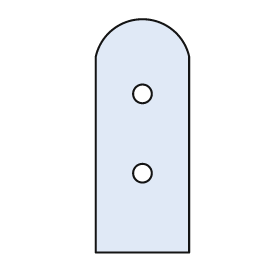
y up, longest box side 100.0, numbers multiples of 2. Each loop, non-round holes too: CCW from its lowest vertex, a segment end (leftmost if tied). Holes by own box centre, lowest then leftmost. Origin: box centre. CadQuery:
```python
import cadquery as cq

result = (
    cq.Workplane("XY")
    .moveTo(-20.0, -50.0)
    .lineTo(20.0, -50.0)
    .lineTo(20.0, 34.0)
    .threePointArc((0.0, 50.0), (-20.0, 34.0))
    .close()
    .moveTo(0.0, -16.0)
    .circle(4.0)
    .moveTo(0.0, 18.0)
    .circle(4.0)
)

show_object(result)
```